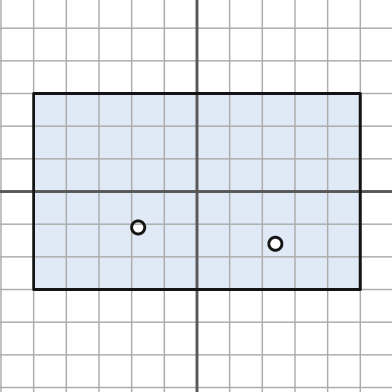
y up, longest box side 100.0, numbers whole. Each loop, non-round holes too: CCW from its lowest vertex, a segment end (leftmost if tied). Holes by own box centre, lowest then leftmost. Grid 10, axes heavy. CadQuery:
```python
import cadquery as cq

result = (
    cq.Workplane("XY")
    .moveTo(-50.0, -30.0)
    .lineTo(50.0, -30.0)
    .lineTo(50.0, 30.0)
    .lineTo(-50.0, 30.0)
    .close()
    .moveTo(24.0, -16.0)
    .circle(2.0)
    .moveTo(-18.0, -11.0)
    .circle(2.0)
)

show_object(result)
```